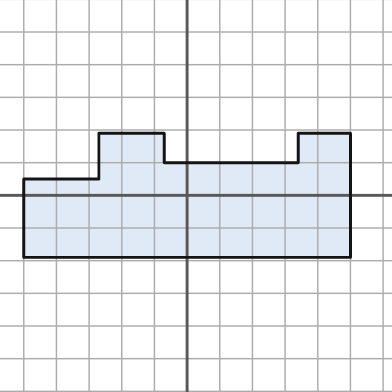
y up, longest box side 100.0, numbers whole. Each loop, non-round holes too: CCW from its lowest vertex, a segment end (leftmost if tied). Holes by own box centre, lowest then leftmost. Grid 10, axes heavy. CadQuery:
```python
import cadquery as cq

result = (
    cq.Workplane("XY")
    .moveTo(-50.0, -19.0)
    .lineTo(50.0, -19.0)
    .lineTo(50.0, 19.0)
    .lineTo(34.0, 19.0)
    .lineTo(34.0, 10.0)
    .lineTo(-7.0, 10.0)
    .lineTo(-7.0, 19.0)
    .lineTo(-27.0, 19.0)
    .lineTo(-27.0, 5.0)
    .lineTo(-50.0, 5.0)
    .close()
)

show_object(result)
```